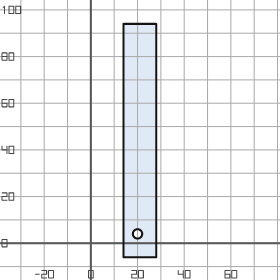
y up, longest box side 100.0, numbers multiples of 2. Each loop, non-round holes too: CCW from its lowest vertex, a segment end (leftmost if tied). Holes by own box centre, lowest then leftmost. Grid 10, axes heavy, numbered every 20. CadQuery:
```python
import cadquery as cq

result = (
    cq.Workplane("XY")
    .moveTo(14.0, -6.0)
    .lineTo(28.0, -6.0)
    .lineTo(28.0, 94.0)
    .lineTo(14.0, 94.0)
    .close()
    .moveTo(20.0, 4.0)
    .circle(2.0)
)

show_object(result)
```